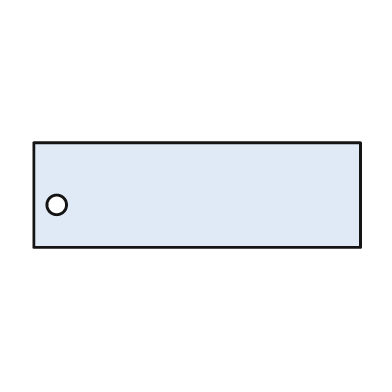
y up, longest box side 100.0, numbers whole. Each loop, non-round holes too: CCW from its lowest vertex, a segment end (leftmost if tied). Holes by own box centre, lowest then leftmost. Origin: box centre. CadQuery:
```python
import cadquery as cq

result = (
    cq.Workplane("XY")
    .moveTo(-50.0, -16.0)
    .lineTo(50.0, -16.0)
    .lineTo(50.0, 16.0)
    .lineTo(-50.0, 16.0)
    .close()
    .moveTo(-43.0, -3.0)
    .circle(3.0)
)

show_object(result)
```